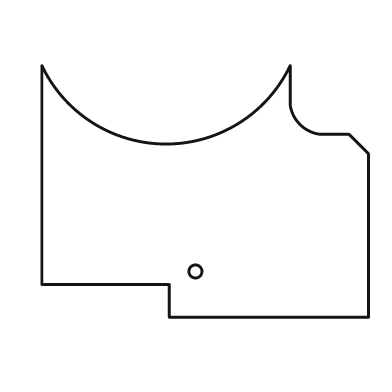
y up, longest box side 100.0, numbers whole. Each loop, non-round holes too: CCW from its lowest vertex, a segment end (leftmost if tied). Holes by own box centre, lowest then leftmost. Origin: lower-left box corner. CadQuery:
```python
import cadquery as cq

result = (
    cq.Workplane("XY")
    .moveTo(39.0, 0.0)
    .lineTo(100.0, 0.0)
    .lineTo(100.0, 50.0)
    .lineTo(94.0, 56.0)
    .lineTo(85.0, 56.0)
    .threePointArc((79.0, 59.0), (76.0, 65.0))
    .lineTo(76.0, 77.0)
    .threePointArc((38.0, 53.0), (0.0, 77.0))
    .lineTo(0.0, 10.0)
    .lineTo(39.0, 10.0)
    .close()
    .moveTo(47.0, 14.0)
    .circle(2.0)
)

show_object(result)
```